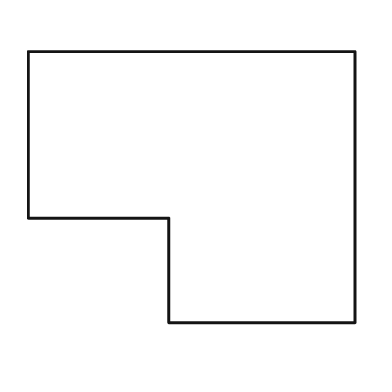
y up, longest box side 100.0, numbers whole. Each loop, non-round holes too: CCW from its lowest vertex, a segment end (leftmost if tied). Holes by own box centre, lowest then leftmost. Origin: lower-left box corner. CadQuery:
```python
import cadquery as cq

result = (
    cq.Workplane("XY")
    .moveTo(43.0, 0.0)
    .lineTo(100.0, 0.0)
    .lineTo(100.0, 83.0)
    .lineTo(0.0, 83.0)
    .lineTo(0.0, 32.0)
    .lineTo(43.0, 32.0)
    .close()
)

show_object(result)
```